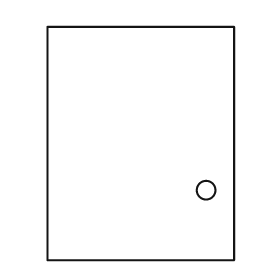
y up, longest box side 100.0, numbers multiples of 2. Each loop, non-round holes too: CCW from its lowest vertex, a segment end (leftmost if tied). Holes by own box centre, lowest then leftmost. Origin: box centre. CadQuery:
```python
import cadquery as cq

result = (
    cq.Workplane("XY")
    .moveTo(-40.0, -50.0)
    .lineTo(40.0, -50.0)
    .lineTo(40.0, 50.0)
    .lineTo(-40.0, 50.0)
    .close()
    .moveTo(28.0, -20.0)
    .circle(4.0)
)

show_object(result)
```